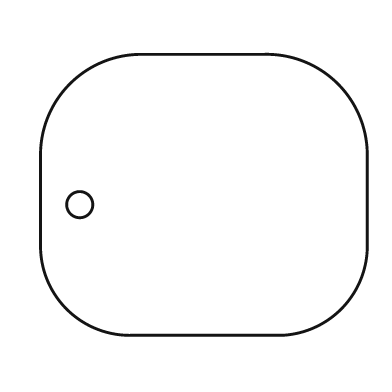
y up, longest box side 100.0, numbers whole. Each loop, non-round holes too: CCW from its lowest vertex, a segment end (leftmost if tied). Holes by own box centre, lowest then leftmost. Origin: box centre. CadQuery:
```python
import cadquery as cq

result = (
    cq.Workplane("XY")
    .moveTo(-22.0, -43.0)
    .lineTo(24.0, -43.0)
    .threePointArc((42.0, -35.0), (50.0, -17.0))
    .lineTo(50.0, 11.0)
    .threePointArc((41.0, 34.0), (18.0, 43.0))
    .lineTo(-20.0, 43.0)
    .threePointArc((-41.0, 34.0), (-50.0, 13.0))
    .lineTo(-50.0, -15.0)
    .threePointArc((-42.0, -35.0), (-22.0, -43.0))
    .close()
    .moveTo(-38.0, -3.0)
    .circle(4.0)
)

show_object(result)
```